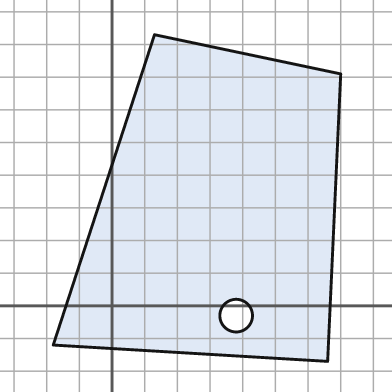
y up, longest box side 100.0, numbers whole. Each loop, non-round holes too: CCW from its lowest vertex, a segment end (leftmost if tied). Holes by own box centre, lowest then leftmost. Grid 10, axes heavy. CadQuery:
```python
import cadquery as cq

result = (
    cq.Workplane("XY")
    .moveTo(66.0, -17.0)
    .lineTo(70.0, 71.0)
    .lineTo(13.0, 83.0)
    .lineTo(-18.0, -12.0)
    .close()
    .moveTo(38.0, -3.0)
    .circle(5.0)
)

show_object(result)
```